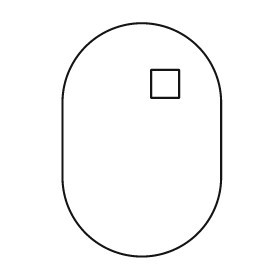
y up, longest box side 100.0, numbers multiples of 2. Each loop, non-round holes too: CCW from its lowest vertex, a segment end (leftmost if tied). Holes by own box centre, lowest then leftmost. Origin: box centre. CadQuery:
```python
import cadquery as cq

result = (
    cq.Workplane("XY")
    .moveTo(-34.0, -16.0)
    .threePointArc((0.0, -50.0), (34.0, -16.0))
    .lineTo(34.0, 16.0)
    .threePointArc((0.0, 50.0), (-34.0, 16.0))
    .close()
    .moveTo(4.0, 18.0)
    .lineTo(16.0, 18.0)
    .lineTo(16.0, 30.0)
    .lineTo(4.0, 30.0)
    .close()
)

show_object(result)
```